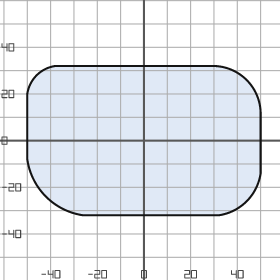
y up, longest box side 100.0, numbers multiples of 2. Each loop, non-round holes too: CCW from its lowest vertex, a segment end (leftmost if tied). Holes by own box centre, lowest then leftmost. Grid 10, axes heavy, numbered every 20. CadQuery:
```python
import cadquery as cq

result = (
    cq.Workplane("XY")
    .moveTo(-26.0, -32.0)
    .lineTo(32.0, -32.0)
    .threePointArc((44.0, -26.0), (50.0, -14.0))
    .lineTo(50.0, 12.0)
    .threePointArc((44.0, 26.0), (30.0, 32.0))
    .lineTo(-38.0, 32.0)
    .threePointArc((-46.0, 28.0), (-50.0, 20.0))
    .lineTo(-50.0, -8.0)
    .threePointArc((-42.0, -24.0), (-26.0, -32.0))
    .close()
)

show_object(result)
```